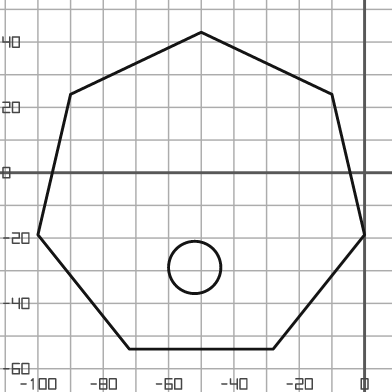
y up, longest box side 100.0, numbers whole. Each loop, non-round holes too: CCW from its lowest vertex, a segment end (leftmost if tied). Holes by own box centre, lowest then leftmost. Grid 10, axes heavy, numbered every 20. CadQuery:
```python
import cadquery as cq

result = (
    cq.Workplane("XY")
    .moveTo(-72.0, -54.0)
    .lineTo(-28.0, -54.0)
    .lineTo(0.0, -19.0)
    .lineTo(-10.0, 24.0)
    .lineTo(-50.0, 43.0)
    .lineTo(-90.0, 24.0)
    .lineTo(-100.0, -19.0)
    .close()
    .moveTo(-52.0, -29.0)
    .circle(8.0)
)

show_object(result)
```